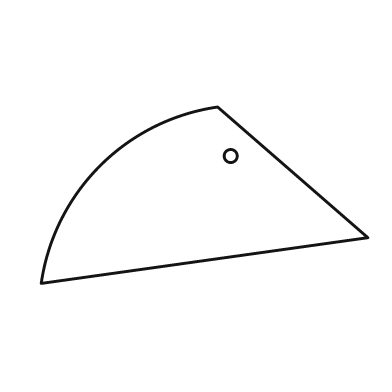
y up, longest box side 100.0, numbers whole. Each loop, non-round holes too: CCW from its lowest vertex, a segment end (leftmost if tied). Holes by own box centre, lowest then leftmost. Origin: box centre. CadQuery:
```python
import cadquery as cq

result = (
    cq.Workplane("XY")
    .moveTo(-50.0, -27.0)
    .lineTo(50.0, -13.0)
    .lineTo(4.0, 27.0)
    .threePointArc((-32.0, 9.0), (-50.0, -27.0))
    .close()
    .moveTo(8.0, 12.0)
    .circle(2.0)
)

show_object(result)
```